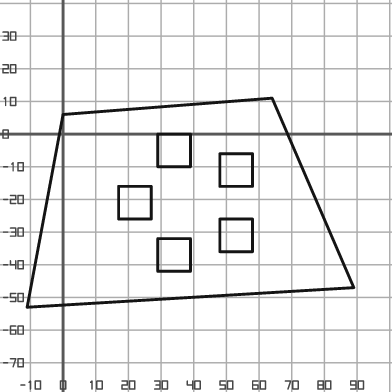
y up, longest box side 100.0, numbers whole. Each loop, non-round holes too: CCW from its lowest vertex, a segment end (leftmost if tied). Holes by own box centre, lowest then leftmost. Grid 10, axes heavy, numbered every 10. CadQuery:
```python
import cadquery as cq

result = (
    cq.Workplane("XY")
    .moveTo(-11.0, -53.0)
    .lineTo(89.0, -47.0)
    .lineTo(64.0, 11.0)
    .lineTo(0.0, 6.0)
    .close()
    .moveTo(29.0, -42.0)
    .lineTo(39.0, -42.0)
    .lineTo(39.0, -32.0)
    .lineTo(29.0, -32.0)
    .close()
    .moveTo(48.0, -36.0)
    .lineTo(58.0, -36.0)
    .lineTo(58.0, -26.0)
    .lineTo(48.0, -26.0)
    .close()
    .moveTo(17.0, -26.0)
    .lineTo(27.0, -26.0)
    .lineTo(27.0, -16.0)
    .lineTo(17.0, -16.0)
    .close()
    .moveTo(48.0, -16.0)
    .lineTo(58.0, -16.0)
    .lineTo(58.0, -6.0)
    .lineTo(48.0, -6.0)
    .close()
    .moveTo(29.0, -10.0)
    .lineTo(39.0, -10.0)
    .lineTo(39.0, 0.0)
    .lineTo(29.0, 0.0)
    .close()
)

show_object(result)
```